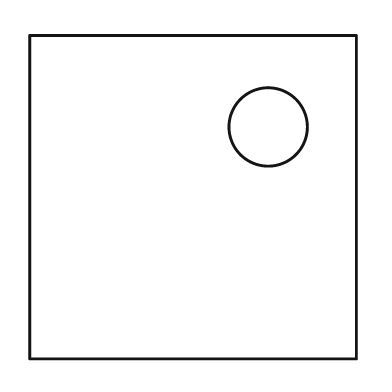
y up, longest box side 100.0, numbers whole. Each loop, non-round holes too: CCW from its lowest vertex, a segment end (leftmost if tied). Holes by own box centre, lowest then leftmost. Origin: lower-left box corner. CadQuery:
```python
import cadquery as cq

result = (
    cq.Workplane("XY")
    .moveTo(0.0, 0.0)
    .lineTo(100.0, 0.0)
    .lineTo(100.0, 99.0)
    .lineTo(0.0, 99.0)
    .close()
    .moveTo(73.0, 71.0)
    .circle(12.0)
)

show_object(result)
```